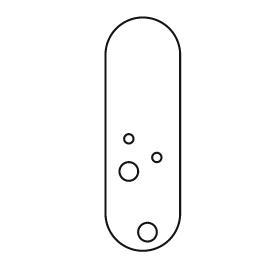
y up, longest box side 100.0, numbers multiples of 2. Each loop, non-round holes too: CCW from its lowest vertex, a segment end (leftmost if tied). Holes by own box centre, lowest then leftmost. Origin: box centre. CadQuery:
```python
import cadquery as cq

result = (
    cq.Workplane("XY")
    .moveTo(-16.0, -34.0)
    .threePointArc((0.0, -50.0), (16.0, -34.0))
    .lineTo(16.0, 34.0)
    .threePointArc((0.0, 50.0), (-16.0, 34.0))
    .close()
    .moveTo(2.0, -42.0)
    .circle(4.0)
    .moveTo(-6.0, -16.0)
    .circle(4.0)
    .moveTo(6.0, -10.0)
    .circle(2.0)
    .moveTo(-6.0, -2.0)
    .circle(2.0)
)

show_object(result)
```